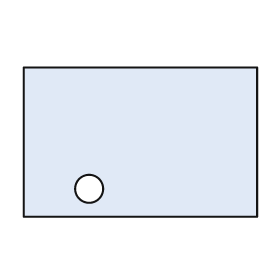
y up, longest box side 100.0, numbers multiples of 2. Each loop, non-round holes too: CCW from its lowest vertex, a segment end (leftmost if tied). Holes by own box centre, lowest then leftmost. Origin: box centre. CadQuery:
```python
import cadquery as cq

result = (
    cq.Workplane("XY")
    .moveTo(-50.0, -32.0)
    .lineTo(50.0, -32.0)
    .lineTo(50.0, 32.0)
    .lineTo(-50.0, 32.0)
    .close()
    .moveTo(-22.0, -20.0)
    .circle(6.0)
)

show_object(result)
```